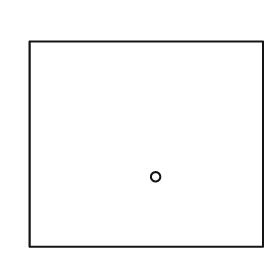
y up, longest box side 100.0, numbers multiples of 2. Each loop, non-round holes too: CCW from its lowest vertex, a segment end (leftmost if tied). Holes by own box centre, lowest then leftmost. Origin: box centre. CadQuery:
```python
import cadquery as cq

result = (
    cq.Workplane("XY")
    .moveTo(-50.0, -44.0)
    .lineTo(50.0, -44.0)
    .lineTo(50.0, 44.0)
    .lineTo(-50.0, 44.0)
    .close()
    .moveTo(4.0, -14.0)
    .circle(2.0)
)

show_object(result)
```